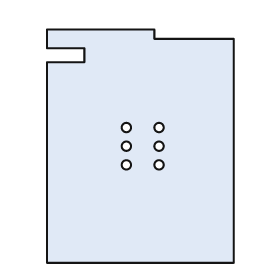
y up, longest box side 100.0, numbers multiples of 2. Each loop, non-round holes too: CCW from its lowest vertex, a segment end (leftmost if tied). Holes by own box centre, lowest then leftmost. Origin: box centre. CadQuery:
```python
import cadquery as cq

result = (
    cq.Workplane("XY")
    .moveTo(-40.0, -50.0)
    .lineTo(40.0, -50.0)
    .lineTo(40.0, 46.0)
    .lineTo(6.0, 46.0)
    .lineTo(6.0, 50.0)
    .lineTo(-40.0, 50.0)
    .lineTo(-40.0, 42.0)
    .lineTo(-24.0, 42.0)
    .lineTo(-24.0, 36.0)
    .lineTo(-40.0, 36.0)
    .close()
    .moveTo(-6.0, -8.0)
    .circle(2.0)
    .moveTo(8.0, -8.0)
    .circle(2.0)
    .moveTo(-6.0, 0.0)
    .circle(2.0)
    .moveTo(8.0, 0.0)
    .circle(2.0)
    .moveTo(-6.0, 8.0)
    .circle(2.0)
    .moveTo(8.0, 8.0)
    .circle(2.0)
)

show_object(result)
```